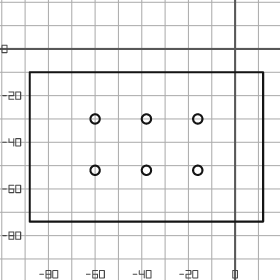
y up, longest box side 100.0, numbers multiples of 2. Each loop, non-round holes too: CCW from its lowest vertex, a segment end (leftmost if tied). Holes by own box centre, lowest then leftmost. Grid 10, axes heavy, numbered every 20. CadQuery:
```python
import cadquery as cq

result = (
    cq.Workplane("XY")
    .moveTo(-88.0, -74.0)
    .lineTo(12.0, -74.0)
    .lineTo(12.0, -10.0)
    .lineTo(-88.0, -10.0)
    .close()
    .moveTo(-60.0, -52.0)
    .circle(2.0)
    .moveTo(-38.0, -52.0)
    .circle(2.0)
    .moveTo(-16.0, -52.0)
    .circle(2.0)
    .moveTo(-60.0, -30.0)
    .circle(2.0)
    .moveTo(-38.0, -30.0)
    .circle(2.0)
    .moveTo(-16.0, -30.0)
    .circle(2.0)
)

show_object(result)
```